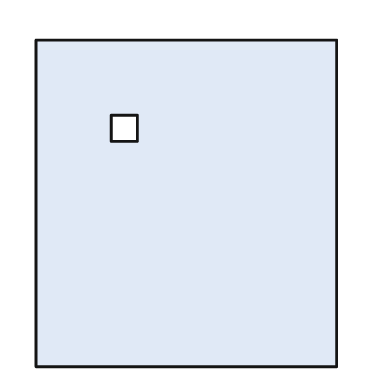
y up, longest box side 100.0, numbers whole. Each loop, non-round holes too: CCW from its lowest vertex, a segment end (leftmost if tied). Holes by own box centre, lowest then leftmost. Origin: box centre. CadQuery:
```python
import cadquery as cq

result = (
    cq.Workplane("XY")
    .moveTo(-46.0, -50.0)
    .lineTo(46.0, -50.0)
    .lineTo(46.0, 50.0)
    .lineTo(-46.0, 50.0)
    .close()
    .moveTo(-23.0, 19.0)
    .lineTo(-15.0, 19.0)
    .lineTo(-15.0, 27.0)
    .lineTo(-23.0, 27.0)
    .close()
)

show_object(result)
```